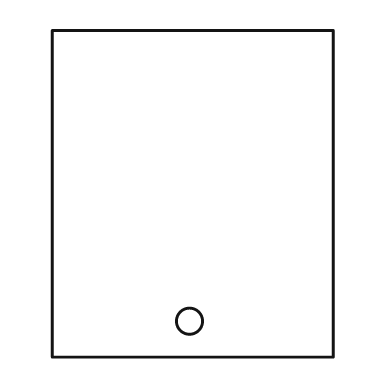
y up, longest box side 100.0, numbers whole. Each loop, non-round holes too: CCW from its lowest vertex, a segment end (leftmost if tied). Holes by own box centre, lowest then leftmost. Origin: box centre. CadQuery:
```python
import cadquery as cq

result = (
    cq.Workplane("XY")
    .moveTo(-43.0, -50.0)
    .lineTo(43.0, -50.0)
    .lineTo(43.0, 50.0)
    .lineTo(-43.0, 50.0)
    .close()
    .moveTo(-1.0, -39.0)
    .circle(4.0)
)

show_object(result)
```